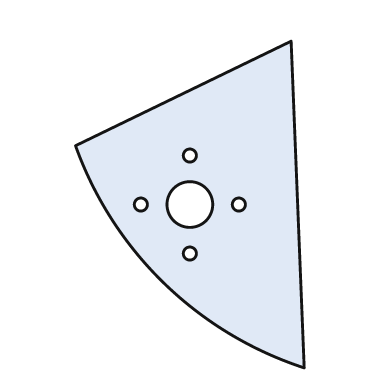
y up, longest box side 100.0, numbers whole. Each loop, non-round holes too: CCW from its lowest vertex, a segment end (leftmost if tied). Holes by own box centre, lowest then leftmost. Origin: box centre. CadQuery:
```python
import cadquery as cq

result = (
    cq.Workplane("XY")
    .moveTo(35.0, -50.0)
    .lineTo(31.0, 50.0)
    .lineTo(-35.0, 18.0)
    .threePointArc((-8.0, -24.0), (35.0, -50.0))
    .close()
    .moveTo(0.0, -15.0)
    .circle(2.0)
    .moveTo(-15.0, 0.0)
    .circle(2.0)
    .moveTo(0.0, 0.0)
    .circle(7.0)
    .moveTo(15.0, 0.0)
    .circle(2.0)
    .moveTo(0.0, 15.0)
    .circle(2.0)
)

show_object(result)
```